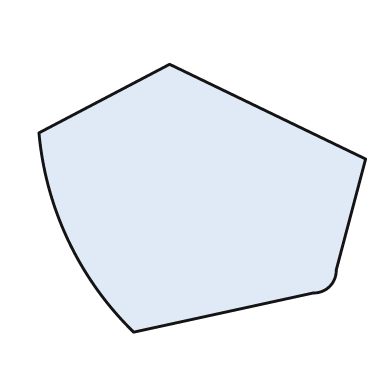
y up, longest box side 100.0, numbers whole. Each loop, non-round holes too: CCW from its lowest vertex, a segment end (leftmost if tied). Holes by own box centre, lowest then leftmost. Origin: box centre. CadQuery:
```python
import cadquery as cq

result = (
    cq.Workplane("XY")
    .moveTo(-21.0, -41.0)
    .lineTo(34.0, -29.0)
    .threePointArc((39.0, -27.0), (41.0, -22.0))
    .lineTo(50.0, 12.0)
    .lineTo(-10.0, 41.0)
    .lineTo(-50.0, 20.0)
    .threePointArc((-41.0, -13.0), (-21.0, -41.0))
    .close()
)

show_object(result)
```